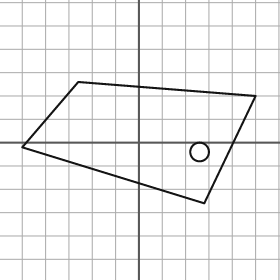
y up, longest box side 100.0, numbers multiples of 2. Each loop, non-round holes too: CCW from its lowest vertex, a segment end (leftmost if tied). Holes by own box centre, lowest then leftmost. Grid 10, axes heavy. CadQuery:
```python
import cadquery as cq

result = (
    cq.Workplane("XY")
    .moveTo(28.0, -26.0)
    .lineTo(50.0, 20.0)
    .lineTo(-26.0, 26.0)
    .lineTo(-50.0, -2.0)
    .close()
    .moveTo(26.0, -4.0)
    .circle(4.0)
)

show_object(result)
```